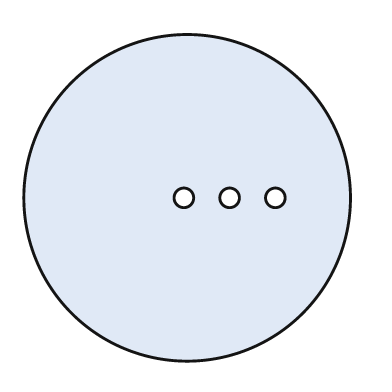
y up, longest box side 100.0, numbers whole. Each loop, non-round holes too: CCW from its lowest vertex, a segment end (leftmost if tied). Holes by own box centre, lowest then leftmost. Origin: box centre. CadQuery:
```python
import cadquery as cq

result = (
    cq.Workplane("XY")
    .moveTo(0.0, 0.0)
    .circle(50.0)
    .moveTo(-1.0, 0.0)
    .circle(3.0)
    .moveTo(13.0, 0.0)
    .circle(3.0)
    .moveTo(27.0, 0.0)
    .circle(3.0)
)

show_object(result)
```